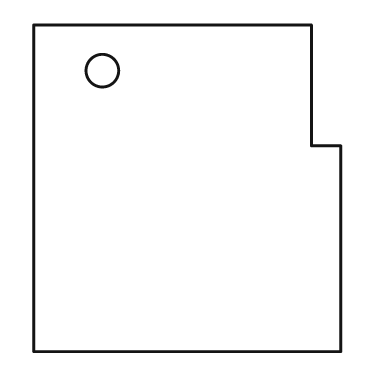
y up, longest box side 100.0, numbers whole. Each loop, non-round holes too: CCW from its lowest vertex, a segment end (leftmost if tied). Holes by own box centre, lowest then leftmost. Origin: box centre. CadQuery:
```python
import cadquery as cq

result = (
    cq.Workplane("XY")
    .moveTo(-47.0, -50.0)
    .lineTo(47.0, -50.0)
    .lineTo(47.0, 13.0)
    .lineTo(38.0, 13.0)
    .lineTo(38.0, 50.0)
    .lineTo(-47.0, 50.0)
    .close()
    .moveTo(-26.0, 36.0)
    .circle(5.0)
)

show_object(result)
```